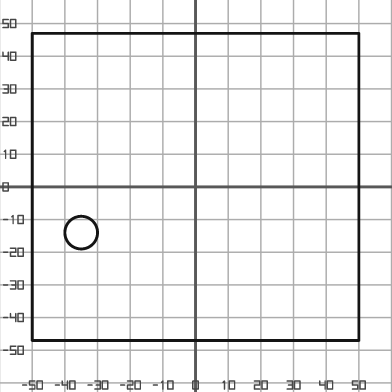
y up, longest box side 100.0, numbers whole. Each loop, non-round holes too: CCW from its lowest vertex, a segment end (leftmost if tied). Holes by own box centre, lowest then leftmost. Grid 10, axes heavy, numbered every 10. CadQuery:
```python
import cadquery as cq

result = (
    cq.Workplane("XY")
    .moveTo(-50.0, -47.0)
    .lineTo(50.0, -47.0)
    .lineTo(50.0, 47.0)
    .lineTo(-50.0, 47.0)
    .close()
    .moveTo(-35.0, -14.0)
    .circle(5.0)
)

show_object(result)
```